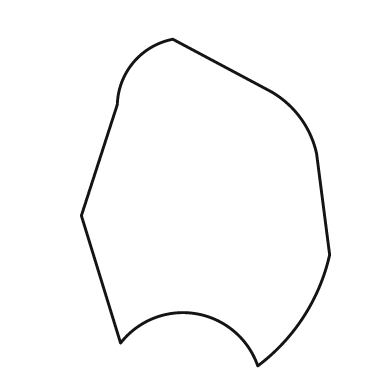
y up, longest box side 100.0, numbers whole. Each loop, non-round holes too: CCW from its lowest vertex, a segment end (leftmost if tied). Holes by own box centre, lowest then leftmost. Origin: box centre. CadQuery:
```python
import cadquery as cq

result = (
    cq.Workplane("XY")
    .moveTo(16.0, -50.0)
    .threePointArc((30.0, -35.0), (38.0, -16.0))
    .lineTo(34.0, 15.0)
    .threePointArc((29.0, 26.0), (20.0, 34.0))
    .lineTo(-10.0, 50.0)
    .threePointArc((-22.0, 43.0), (-27.0, 30.0))
    .lineTo(-38.0, -4.0)
    .lineTo(-26.0, -43.0)
    .threePointArc((-3.0, -34.0), (16.0, -50.0))
    .close()
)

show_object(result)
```